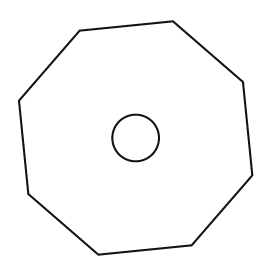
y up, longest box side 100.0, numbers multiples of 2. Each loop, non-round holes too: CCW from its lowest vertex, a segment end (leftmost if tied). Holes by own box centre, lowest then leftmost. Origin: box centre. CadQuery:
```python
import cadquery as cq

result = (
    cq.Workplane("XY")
    .moveTo(-16.0, -50.0)
    .lineTo(24.0, -46.0)
    .lineTo(50.0, -16.0)
    .lineTo(46.0, 24.0)
    .lineTo(16.0, 50.0)
    .lineTo(-24.0, 46.0)
    .lineTo(-50.0, 16.0)
    .lineTo(-46.0, -24.0)
    .close()
    .moveTo(0.0, 0.0)
    .circle(10.0)
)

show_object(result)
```